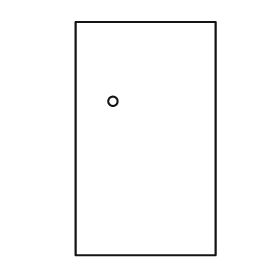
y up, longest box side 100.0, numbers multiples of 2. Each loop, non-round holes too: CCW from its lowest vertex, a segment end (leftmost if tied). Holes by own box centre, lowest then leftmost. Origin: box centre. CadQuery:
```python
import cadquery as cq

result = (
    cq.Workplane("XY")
    .moveTo(-30.0, -50.0)
    .lineTo(30.0, -50.0)
    .lineTo(30.0, 50.0)
    .lineTo(-30.0, 50.0)
    .close()
    .moveTo(-14.0, 16.0)
    .circle(2.0)
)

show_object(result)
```